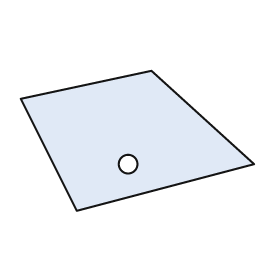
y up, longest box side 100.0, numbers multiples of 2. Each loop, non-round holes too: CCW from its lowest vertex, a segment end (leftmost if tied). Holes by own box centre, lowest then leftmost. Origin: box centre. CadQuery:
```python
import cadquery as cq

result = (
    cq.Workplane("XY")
    .moveTo(-26.0, -30.0)
    .lineTo(50.0, -10.0)
    .lineTo(6.0, 30.0)
    .lineTo(-50.0, 18.0)
    .close()
    .moveTo(-4.0, -10.0)
    .circle(4.0)
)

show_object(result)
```